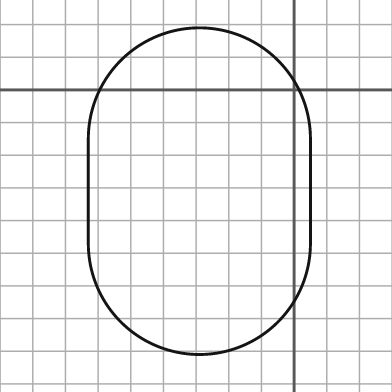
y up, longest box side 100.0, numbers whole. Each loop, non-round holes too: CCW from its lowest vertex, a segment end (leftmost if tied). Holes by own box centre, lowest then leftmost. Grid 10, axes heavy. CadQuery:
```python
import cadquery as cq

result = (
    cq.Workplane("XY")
    .moveTo(-63.0, -47.0)
    .threePointArc((-29.0, -81.0), (5.0, -47.0))
    .lineTo(5.0, -15.0)
    .threePointArc((-29.0, 19.0), (-63.0, -15.0))
    .close()
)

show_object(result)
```